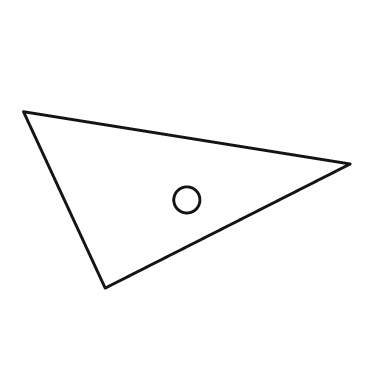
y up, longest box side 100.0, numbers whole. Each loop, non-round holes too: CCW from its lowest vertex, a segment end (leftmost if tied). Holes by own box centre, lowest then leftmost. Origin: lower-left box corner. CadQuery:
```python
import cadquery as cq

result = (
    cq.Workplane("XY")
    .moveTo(25.0, 0.0)
    .lineTo(100.0, 38.0)
    .lineTo(0.0, 54.0)
    .close()
    .moveTo(50.0, 27.0)
    .circle(4.0)
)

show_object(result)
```